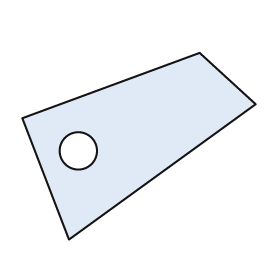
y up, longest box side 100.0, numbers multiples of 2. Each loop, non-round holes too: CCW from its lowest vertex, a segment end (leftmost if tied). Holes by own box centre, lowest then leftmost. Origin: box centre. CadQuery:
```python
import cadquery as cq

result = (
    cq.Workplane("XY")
    .moveTo(-30.0, -40.0)
    .lineTo(50.0, 18.0)
    .lineTo(26.0, 40.0)
    .lineTo(-50.0, 12.0)
    .close()
    .moveTo(-26.0, -2.0)
    .circle(8.0)
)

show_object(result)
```